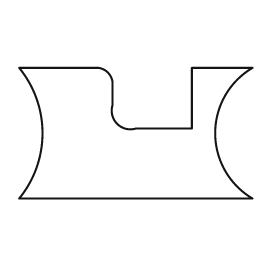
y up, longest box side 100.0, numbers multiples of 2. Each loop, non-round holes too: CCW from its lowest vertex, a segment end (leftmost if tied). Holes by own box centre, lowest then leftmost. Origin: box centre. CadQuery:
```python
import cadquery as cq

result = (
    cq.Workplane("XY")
    .moveTo(-50.0, -28.0)
    .lineTo(50.0, -28.0)
    .threePointArc((34.0, 0.0), (50.0, 28.0))
    .lineTo(24.0, 28.0)
    .lineTo(24.0, 2.0)
    .lineTo(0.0, 2.0)
    .threePointArc((-8.0, 4.0), (-10.0, 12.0))
    .lineTo(-10.0, 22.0)
    .threePointArc((-12.0, 26.0), (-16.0, 28.0))
    .lineTo(-50.0, 28.0)
    .threePointArc((-40.0, 0.0), (-50.0, -28.0))
    .close()
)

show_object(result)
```